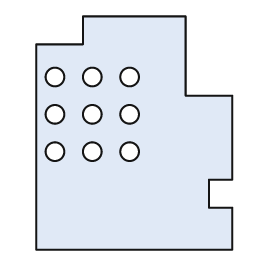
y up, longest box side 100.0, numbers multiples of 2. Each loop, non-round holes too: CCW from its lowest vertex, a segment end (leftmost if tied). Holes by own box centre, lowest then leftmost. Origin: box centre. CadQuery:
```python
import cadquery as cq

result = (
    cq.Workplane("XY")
    .moveTo(-42.0, -50.0)
    .lineTo(42.0, -50.0)
    .lineTo(42.0, -32.0)
    .lineTo(32.0, -32.0)
    .lineTo(32.0, -20.0)
    .lineTo(42.0, -20.0)
    .lineTo(42.0, 16.0)
    .lineTo(22.0, 16.0)
    .lineTo(22.0, 50.0)
    .lineTo(-22.0, 50.0)
    .lineTo(-22.0, 38.0)
    .lineTo(-42.0, 38.0)
    .close()
    .moveTo(-34.0, -8.0)
    .circle(4.0)
    .moveTo(-18.0, -8.0)
    .circle(4.0)
    .moveTo(-2.0, -8.0)
    .circle(4.0)
    .moveTo(-34.0, 8.0)
    .circle(4.0)
    .moveTo(-18.0, 8.0)
    .circle(4.0)
    .moveTo(-2.0, 8.0)
    .circle(4.0)
    .moveTo(-34.0, 24.0)
    .circle(4.0)
    .moveTo(-18.0, 24.0)
    .circle(4.0)
    .moveTo(-2.0, 24.0)
    .circle(4.0)
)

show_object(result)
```